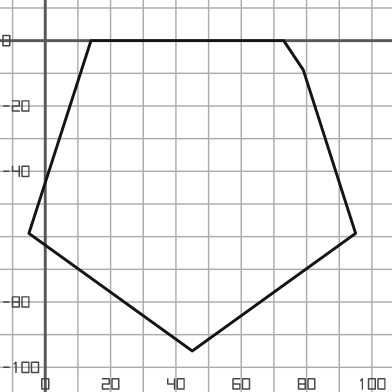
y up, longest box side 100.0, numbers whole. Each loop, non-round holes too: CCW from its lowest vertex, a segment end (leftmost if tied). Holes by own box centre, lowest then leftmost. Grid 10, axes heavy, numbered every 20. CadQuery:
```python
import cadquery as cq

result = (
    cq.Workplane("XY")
    .moveTo(45.0, -95.0)
    .lineTo(95.0, -59.0)
    .lineTo(79.0, -9.0)
    .lineTo(73.0, 0.0)
    .lineTo(14.0, 0.0)
    .lineTo(-5.0, -59.0)
    .close()
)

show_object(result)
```